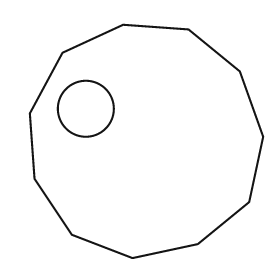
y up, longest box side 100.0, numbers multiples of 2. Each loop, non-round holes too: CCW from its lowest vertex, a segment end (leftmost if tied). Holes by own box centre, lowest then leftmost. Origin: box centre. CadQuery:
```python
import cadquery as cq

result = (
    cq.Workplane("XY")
    .moveTo(-6.0, -50.0)
    .lineTo(22.0, -44.0)
    .lineTo(44.0, -26.0)
    .lineTo(50.0, 2.0)
    .lineTo(40.0, 30.0)
    .lineTo(18.0, 48.0)
    .lineTo(-10.0, 50.0)
    .lineTo(-36.0, 38.0)
    .lineTo(-50.0, 12.0)
    .lineTo(-48.0, -16.0)
    .lineTo(-32.0, -40.0)
    .close()
    .moveTo(-26.0, 14.0)
    .circle(12.0)
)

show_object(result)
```